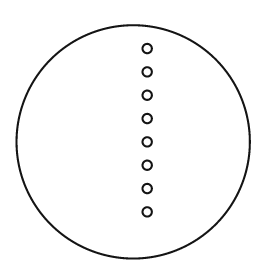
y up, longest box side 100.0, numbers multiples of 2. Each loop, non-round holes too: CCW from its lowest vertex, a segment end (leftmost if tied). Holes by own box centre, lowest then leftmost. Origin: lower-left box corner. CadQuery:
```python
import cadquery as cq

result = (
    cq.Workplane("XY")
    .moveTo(50.0, 50.0)
    .circle(50.0)
    .moveTo(56.0, 20.0)
    .circle(2.0)
    .moveTo(56.0, 30.0)
    .circle(2.0)
    .moveTo(56.0, 40.0)
    .circle(2.0)
    .moveTo(56.0, 50.0)
    .circle(2.0)
    .moveTo(56.0, 60.0)
    .circle(2.0)
    .moveTo(56.0, 70.0)
    .circle(2.0)
    .moveTo(56.0, 80.0)
    .circle(2.0)
    .moveTo(56.0, 90.0)
    .circle(2.0)
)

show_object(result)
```